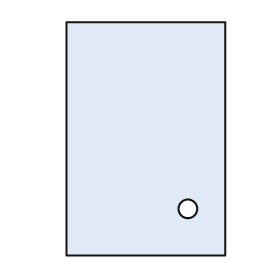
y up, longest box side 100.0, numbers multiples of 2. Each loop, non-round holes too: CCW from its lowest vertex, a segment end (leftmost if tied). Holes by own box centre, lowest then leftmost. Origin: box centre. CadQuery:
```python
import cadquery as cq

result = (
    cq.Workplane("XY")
    .moveTo(-34.0, -50.0)
    .lineTo(34.0, -50.0)
    .lineTo(34.0, 50.0)
    .lineTo(-34.0, 50.0)
    .close()
    .moveTo(18.0, -30.0)
    .circle(4.0)
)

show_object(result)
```